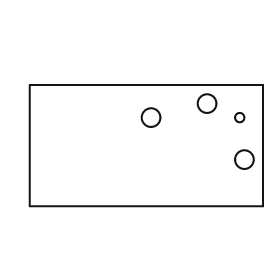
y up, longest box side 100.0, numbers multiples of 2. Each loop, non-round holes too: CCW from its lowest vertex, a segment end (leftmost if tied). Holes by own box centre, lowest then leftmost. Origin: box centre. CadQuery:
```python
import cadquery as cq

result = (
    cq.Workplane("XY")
    .moveTo(-50.0, -26.0)
    .lineTo(50.0, -26.0)
    .lineTo(50.0, 26.0)
    .lineTo(-50.0, 26.0)
    .close()
    .moveTo(42.0, -6.0)
    .circle(4.0)
    .moveTo(2.0, 12.0)
    .circle(4.0)
    .moveTo(40.0, 12.0)
    .circle(2.0)
    .moveTo(26.0, 18.0)
    .circle(4.0)
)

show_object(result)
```